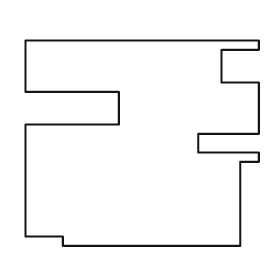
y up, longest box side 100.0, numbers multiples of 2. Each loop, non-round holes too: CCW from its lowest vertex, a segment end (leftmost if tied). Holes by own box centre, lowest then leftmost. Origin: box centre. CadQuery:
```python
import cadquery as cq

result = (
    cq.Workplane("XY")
    .moveTo(-34.0, -44.0)
    .lineTo(42.0, -44.0)
    .lineTo(42.0, -8.0)
    .lineTo(50.0, -8.0)
    .lineTo(50.0, -4.0)
    .lineTo(24.0, -4.0)
    .lineTo(24.0, 4.0)
    .lineTo(50.0, 4.0)
    .lineTo(50.0, 26.0)
    .lineTo(34.0, 26.0)
    .lineTo(34.0, 40.0)
    .lineTo(50.0, 40.0)
    .lineTo(50.0, 44.0)
    .lineTo(-50.0, 44.0)
    .lineTo(-50.0, 22.0)
    .lineTo(-10.0, 22.0)
    .lineTo(-10.0, 8.0)
    .lineTo(-50.0, 8.0)
    .lineTo(-50.0, -40.0)
    .lineTo(-34.0, -40.0)
    .close()
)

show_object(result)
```